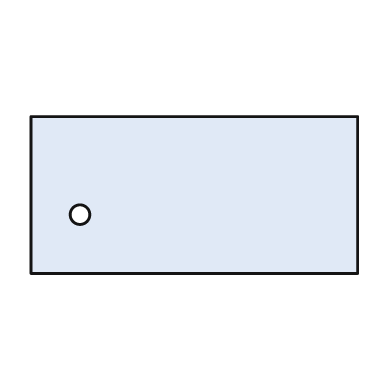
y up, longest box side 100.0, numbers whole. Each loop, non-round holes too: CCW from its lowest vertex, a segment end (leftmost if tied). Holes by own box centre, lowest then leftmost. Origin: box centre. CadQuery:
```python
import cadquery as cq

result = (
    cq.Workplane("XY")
    .moveTo(-50.0, -24.0)
    .lineTo(50.0, -24.0)
    .lineTo(50.0, 24.0)
    .lineTo(-50.0, 24.0)
    .close()
    .moveTo(-35.0, -6.0)
    .circle(3.0)
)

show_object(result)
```